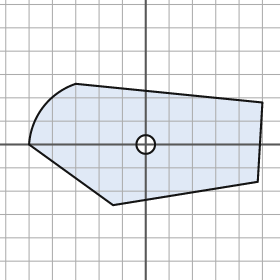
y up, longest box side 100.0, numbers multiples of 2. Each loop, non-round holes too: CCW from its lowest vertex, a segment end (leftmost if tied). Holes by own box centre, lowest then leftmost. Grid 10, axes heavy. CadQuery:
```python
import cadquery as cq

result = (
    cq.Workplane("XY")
    .moveTo(-14.0, -26.0)
    .lineTo(48.0, -16.0)
    .lineTo(50.0, 18.0)
    .lineTo(-30.0, 26.0)
    .threePointArc((-44.0, 16.0), (-50.0, 0.0))
    .close()
    .moveTo(0.0, 0.0)
    .circle(4.0)
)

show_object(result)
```